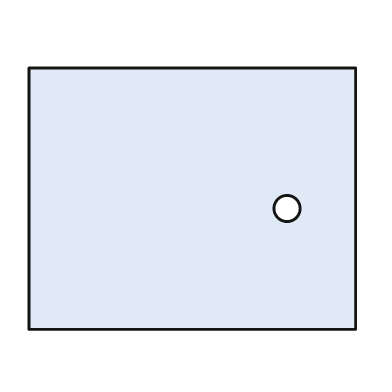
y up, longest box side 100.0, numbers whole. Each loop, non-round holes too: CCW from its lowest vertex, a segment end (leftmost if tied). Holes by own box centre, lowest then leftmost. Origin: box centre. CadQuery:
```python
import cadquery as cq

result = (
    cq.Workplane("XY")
    .moveTo(-50.0, -40.0)
    .lineTo(50.0, -40.0)
    .lineTo(50.0, 40.0)
    .lineTo(-50.0, 40.0)
    .close()
    .moveTo(29.0, -3.0)
    .circle(4.0)
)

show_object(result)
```